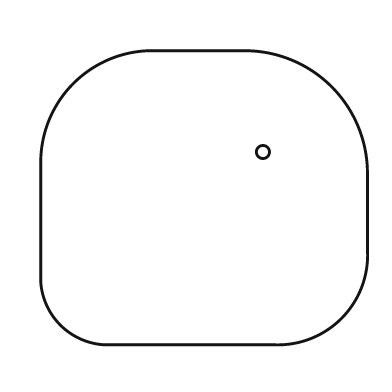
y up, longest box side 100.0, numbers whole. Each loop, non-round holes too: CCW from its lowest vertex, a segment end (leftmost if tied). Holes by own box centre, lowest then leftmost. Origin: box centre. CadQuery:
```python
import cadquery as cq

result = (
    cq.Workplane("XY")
    .moveTo(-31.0, -45.0)
    .lineTo(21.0, -45.0)
    .threePointArc((42.0, -37.0), (50.0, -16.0))
    .lineTo(50.0, 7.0)
    .threePointArc((39.0, 34.0), (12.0, 45.0))
    .lineTo(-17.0, 45.0)
    .threePointArc((-40.0, 35.0), (-50.0, 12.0))
    .lineTo(-50.0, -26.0)
    .threePointArc((-44.0, -39.0), (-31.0, -45.0))
    .close()
    .moveTo(18.0, 14.0)
    .circle(2.0)
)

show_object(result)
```